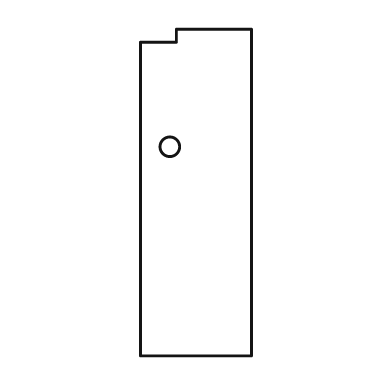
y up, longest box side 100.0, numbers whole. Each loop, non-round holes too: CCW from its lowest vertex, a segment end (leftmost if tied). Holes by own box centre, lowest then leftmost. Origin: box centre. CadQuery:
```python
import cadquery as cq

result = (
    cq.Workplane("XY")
    .moveTo(-17.0, -50.0)
    .lineTo(17.0, -50.0)
    .lineTo(17.0, 50.0)
    .lineTo(-6.0, 50.0)
    .lineTo(-6.0, 46.0)
    .lineTo(-17.0, 46.0)
    .close()
    .moveTo(-8.0, 14.0)
    .circle(3.0)
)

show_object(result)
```